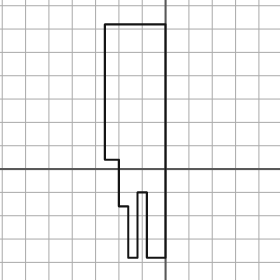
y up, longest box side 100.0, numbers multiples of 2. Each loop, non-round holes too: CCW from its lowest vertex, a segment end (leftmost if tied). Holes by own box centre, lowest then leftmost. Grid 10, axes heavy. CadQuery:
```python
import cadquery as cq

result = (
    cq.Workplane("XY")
    .moveTo(-16.0, -38.0)
    .lineTo(-12.0, -38.0)
    .lineTo(-12.0, -10.0)
    .lineTo(-8.0, -10.0)
    .lineTo(-8.0, -38.0)
    .lineTo(0.0, -38.0)
    .lineTo(0.0, 62.0)
    .lineTo(-26.0, 62.0)
    .lineTo(-26.0, 4.0)
    .lineTo(-20.0, 4.0)
    .lineTo(-20.0, -16.0)
    .lineTo(-16.0, -16.0)
    .close()
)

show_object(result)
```